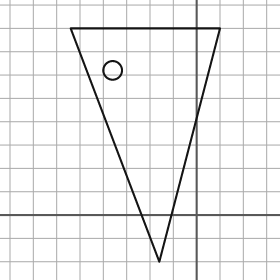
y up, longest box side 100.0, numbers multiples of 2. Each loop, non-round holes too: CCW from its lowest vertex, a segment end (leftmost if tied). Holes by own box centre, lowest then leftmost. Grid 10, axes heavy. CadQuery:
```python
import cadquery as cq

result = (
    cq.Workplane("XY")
    .moveTo(-16.0, -20.0)
    .lineTo(10.0, 80.0)
    .lineTo(-54.0, 80.0)
    .close()
    .moveTo(-36.0, 62.0)
    .circle(4.0)
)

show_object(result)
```